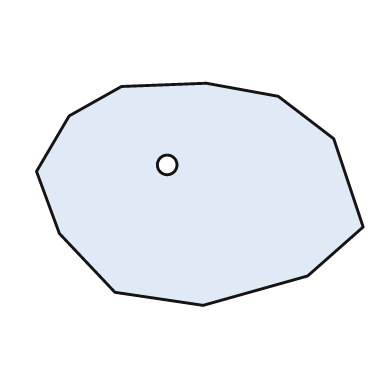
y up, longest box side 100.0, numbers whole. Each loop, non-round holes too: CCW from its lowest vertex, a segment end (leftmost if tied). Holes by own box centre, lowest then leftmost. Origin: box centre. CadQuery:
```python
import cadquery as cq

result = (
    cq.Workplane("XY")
    .moveTo(1.0, -34.0)
    .lineTo(33.0, -25.0)
    .lineTo(50.0, -10.0)
    .lineTo(41.0, 17.0)
    .lineTo(24.0, 30.0)
    .lineTo(2.0, 34.0)
    .lineTo(-24.0, 33.0)
    .lineTo(-40.0, 24.0)
    .lineTo(-50.0, 7.0)
    .lineTo(-43.0, -12.0)
    .lineTo(-26.0, -30.0)
    .close()
    .moveTo(-10.0, 9.0)
    .circle(3.0)
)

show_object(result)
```